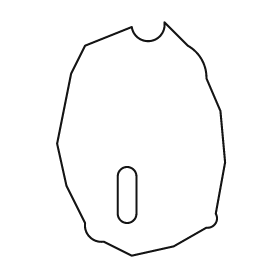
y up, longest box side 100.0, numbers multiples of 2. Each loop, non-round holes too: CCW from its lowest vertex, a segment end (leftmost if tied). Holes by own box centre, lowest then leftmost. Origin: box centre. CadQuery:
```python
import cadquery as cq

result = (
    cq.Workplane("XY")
    .moveTo(-4.0, -50.0)
    .lineTo(14.0, -46.0)
    .lineTo(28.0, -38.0)
    .threePointArc((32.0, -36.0), (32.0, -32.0))
    .lineTo(36.0, -10.0)
    .lineTo(34.0, 12.0)
    .lineTo(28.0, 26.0)
    .threePointArc((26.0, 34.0), (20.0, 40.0))
    .lineTo(10.0, 50.0)
    .threePointArc((4.0, 42.0), (-4.0, 48.0))
    .lineTo(-24.0, 40.0)
    .lineTo(-30.0, 28.0)
    .lineTo(-36.0, -2.0)
    .lineTo(-32.0, -20.0)
    .lineTo(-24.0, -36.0)
    .threePointArc((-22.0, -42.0), (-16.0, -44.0))
    .close()
    .moveTo(-10.0, -32.0)
    .threePointArc((-6.0, -36.0), (-2.0, -32.0))
    .lineTo(-2.0, -16.0)
    .threePointArc((-6.0, -12.0), (-10.0, -16.0))
    .close()
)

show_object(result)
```